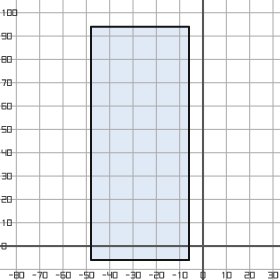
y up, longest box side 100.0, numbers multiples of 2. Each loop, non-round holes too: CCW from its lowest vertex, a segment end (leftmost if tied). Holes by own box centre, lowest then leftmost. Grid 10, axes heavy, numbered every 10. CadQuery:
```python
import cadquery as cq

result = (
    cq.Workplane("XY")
    .moveTo(-48.0, -6.0)
    .lineTo(-6.0, -6.0)
    .lineTo(-6.0, 94.0)
    .lineTo(-48.0, 94.0)
    .close()
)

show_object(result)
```